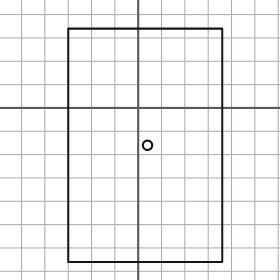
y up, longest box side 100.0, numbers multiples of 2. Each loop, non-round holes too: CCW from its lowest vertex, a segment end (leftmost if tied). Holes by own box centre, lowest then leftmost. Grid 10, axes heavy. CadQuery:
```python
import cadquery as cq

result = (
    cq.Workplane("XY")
    .moveTo(-30.0, -66.0)
    .lineTo(36.0, -66.0)
    .lineTo(36.0, 34.0)
    .lineTo(-30.0, 34.0)
    .close()
    .moveTo(4.0, -16.0)
    .circle(2.0)
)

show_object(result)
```